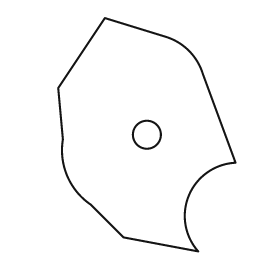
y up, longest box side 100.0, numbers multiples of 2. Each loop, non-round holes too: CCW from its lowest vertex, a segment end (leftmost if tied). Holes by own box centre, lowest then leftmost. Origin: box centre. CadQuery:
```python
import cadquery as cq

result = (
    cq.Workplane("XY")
    .moveTo(22.0, -50.0)
    .threePointArc((18.0, -26.0), (38.0, -12.0))
    .lineTo(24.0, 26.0)
    .threePointArc((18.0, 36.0), (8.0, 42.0))
    .lineTo(-18.0, 50.0)
    .lineTo(-38.0, 20.0)
    .lineTo(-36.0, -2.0)
    .threePointArc((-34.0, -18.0), (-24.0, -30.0))
    .lineTo(-10.0, -44.0)
    .close()
    .moveTo(0.0, 0.0)
    .circle(6.0)
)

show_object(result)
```